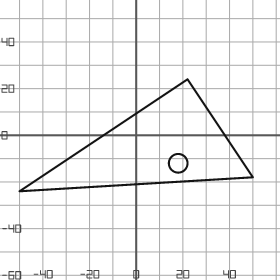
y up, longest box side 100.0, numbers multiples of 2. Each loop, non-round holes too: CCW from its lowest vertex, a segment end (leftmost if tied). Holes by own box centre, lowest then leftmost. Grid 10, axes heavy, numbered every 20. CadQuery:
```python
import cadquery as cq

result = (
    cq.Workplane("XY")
    .moveTo(-50.0, -24.0)
    .lineTo(50.0, -18.0)
    .lineTo(22.0, 24.0)
    .close()
    .moveTo(18.0, -12.0)
    .circle(4.0)
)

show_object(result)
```